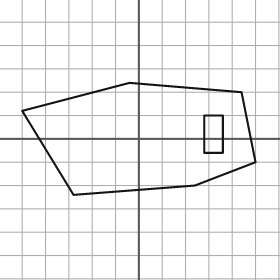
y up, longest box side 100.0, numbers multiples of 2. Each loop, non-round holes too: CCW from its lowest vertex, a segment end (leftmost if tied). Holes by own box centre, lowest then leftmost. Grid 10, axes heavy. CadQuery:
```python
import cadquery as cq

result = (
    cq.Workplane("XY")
    .moveTo(-28.0, -24.0)
    .lineTo(24.0, -20.0)
    .lineTo(50.0, -10.0)
    .lineTo(44.0, 20.0)
    .lineTo(-4.0, 24.0)
    .lineTo(-50.0, 12.0)
    .close()
    .moveTo(28.0, -6.0)
    .lineTo(36.0, -6.0)
    .lineTo(36.0, 10.0)
    .lineTo(28.0, 10.0)
    .close()
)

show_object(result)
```